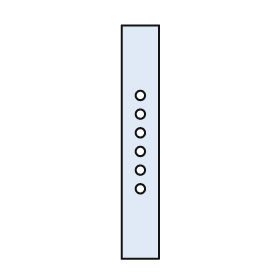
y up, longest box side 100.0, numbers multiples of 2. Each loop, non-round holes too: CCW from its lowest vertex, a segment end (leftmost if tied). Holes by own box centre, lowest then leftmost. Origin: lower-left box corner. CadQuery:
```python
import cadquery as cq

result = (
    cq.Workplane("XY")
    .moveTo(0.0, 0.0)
    .lineTo(16.0, 0.0)
    .lineTo(16.0, 100.0)
    .lineTo(0.0, 100.0)
    .close()
    .moveTo(8.0, 30.0)
    .circle(2.0)
    .moveTo(8.0, 38.0)
    .circle(2.0)
    .moveTo(8.0, 46.0)
    .circle(2.0)
    .moveTo(8.0, 54.0)
    .circle(2.0)
    .moveTo(8.0, 62.0)
    .circle(2.0)
    .moveTo(8.0, 70.0)
    .circle(2.0)
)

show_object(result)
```